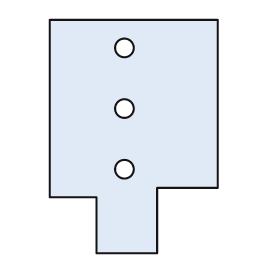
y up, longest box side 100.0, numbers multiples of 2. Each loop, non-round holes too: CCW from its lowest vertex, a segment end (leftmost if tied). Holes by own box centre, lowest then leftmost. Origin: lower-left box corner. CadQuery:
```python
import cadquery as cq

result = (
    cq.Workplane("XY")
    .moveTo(20.0, 0.0)
    .lineTo(46.0, 0.0)
    .lineTo(46.0, 28.0)
    .lineTo(72.0, 28.0)
    .lineTo(72.0, 100.0)
    .lineTo(0.0, 100.0)
    .lineTo(0.0, 24.0)
    .lineTo(20.0, 24.0)
    .close()
    .moveTo(32.0, 36.0)
    .circle(4.0)
    .moveTo(32.0, 62.0)
    .circle(4.0)
    .moveTo(32.0, 88.0)
    .circle(4.0)
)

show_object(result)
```